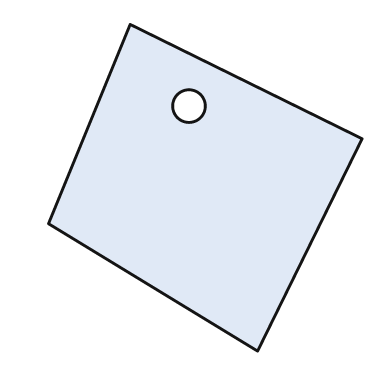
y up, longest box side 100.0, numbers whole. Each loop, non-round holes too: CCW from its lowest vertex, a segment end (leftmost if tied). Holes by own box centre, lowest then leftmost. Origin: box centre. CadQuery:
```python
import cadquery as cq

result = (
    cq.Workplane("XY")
    .moveTo(16.0, -50.0)
    .lineTo(48.0, 15.0)
    .lineTo(-23.0, 50.0)
    .lineTo(-48.0, -11.0)
    .close()
    .moveTo(-5.0, 25.0)
    .circle(5.0)
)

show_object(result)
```